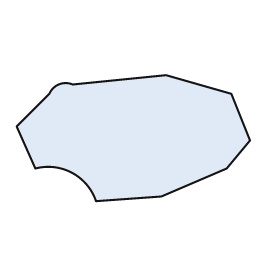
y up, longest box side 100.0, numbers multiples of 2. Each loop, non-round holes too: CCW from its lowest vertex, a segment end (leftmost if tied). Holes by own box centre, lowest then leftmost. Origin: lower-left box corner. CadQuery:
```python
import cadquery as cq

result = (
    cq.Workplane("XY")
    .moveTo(34.0, 0.0)
    .lineTo(62.0, 2.0)
    .lineTo(90.0, 14.0)
    .lineTo(100.0, 26.0)
    .lineTo(92.0, 46.0)
    .lineTo(64.0, 54.0)
    .lineTo(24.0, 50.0)
    .threePointArc((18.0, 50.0), (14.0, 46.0))
    .lineTo(0.0, 32.0)
    .lineTo(8.0, 14.0)
    .threePointArc((24.0, 12.0), (34.0, 0.0))
    .close()
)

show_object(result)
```